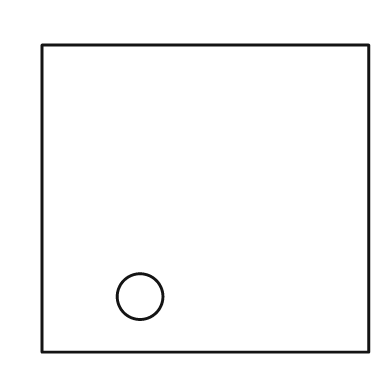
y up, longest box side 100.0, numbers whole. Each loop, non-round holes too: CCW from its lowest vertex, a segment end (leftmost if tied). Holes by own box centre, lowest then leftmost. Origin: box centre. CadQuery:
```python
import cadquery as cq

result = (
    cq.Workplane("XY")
    .moveTo(-50.0, -47.0)
    .lineTo(50.0, -47.0)
    .lineTo(50.0, 47.0)
    .lineTo(-50.0, 47.0)
    .close()
    .moveTo(-20.0, -30.0)
    .circle(7.0)
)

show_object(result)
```